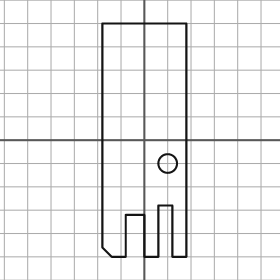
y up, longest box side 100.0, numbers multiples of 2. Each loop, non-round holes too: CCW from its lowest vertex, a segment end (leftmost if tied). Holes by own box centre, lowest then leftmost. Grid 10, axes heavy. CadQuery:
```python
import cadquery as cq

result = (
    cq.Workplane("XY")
    .moveTo(-14.0, -50.0)
    .lineTo(-8.0, -50.0)
    .lineTo(-8.0, -32.0)
    .lineTo(0.0, -32.0)
    .lineTo(0.0, -50.0)
    .lineTo(6.0, -50.0)
    .lineTo(6.0, -28.0)
    .lineTo(12.0, -28.0)
    .lineTo(12.0, -50.0)
    .lineTo(18.0, -50.0)
    .lineTo(18.0, 50.0)
    .lineTo(-18.0, 50.0)
    .lineTo(-18.0, -46.0)
    .close()
    .moveTo(10.0, -10.0)
    .circle(4.0)
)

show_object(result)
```